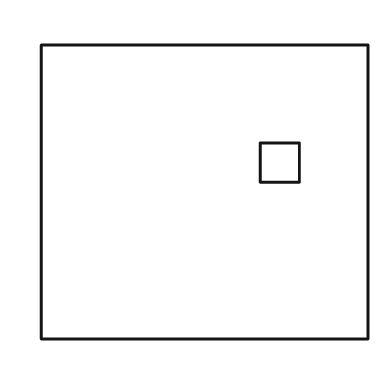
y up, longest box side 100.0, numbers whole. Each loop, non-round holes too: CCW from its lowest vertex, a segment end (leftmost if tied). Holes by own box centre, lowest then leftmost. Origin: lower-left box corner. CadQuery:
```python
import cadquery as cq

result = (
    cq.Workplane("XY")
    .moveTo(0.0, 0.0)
    .lineTo(100.0, 0.0)
    .lineTo(100.0, 90.0)
    .lineTo(0.0, 90.0)
    .close()
    .moveTo(67.0, 48.0)
    .lineTo(79.0, 48.0)
    .lineTo(79.0, 60.0)
    .lineTo(67.0, 60.0)
    .close()
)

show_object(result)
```